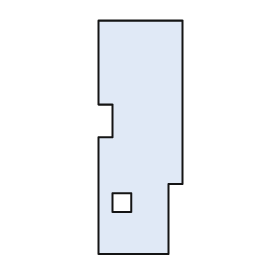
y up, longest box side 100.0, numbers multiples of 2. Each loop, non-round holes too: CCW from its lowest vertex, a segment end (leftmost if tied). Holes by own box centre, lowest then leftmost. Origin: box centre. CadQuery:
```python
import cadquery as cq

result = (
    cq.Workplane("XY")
    .moveTo(-18.0, -50.0)
    .lineTo(12.0, -50.0)
    .lineTo(12.0, -20.0)
    .lineTo(18.0, -20.0)
    .lineTo(18.0, 50.0)
    .lineTo(-18.0, 50.0)
    .lineTo(-18.0, 14.0)
    .lineTo(-12.0, 14.0)
    .lineTo(-12.0, 0.0)
    .lineTo(-18.0, 0.0)
    .close()
    .moveTo(-12.0, -32.0)
    .lineTo(-4.0, -32.0)
    .lineTo(-4.0, -24.0)
    .lineTo(-12.0, -24.0)
    .close()
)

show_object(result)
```